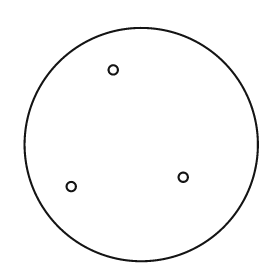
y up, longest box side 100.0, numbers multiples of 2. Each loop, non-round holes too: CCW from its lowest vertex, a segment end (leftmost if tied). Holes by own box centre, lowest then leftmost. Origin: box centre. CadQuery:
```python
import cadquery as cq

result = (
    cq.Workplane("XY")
    .moveTo(0.0, 0.0)
    .circle(50.0)
    .moveTo(-30.0, -18.0)
    .circle(2.0)
    .moveTo(18.0, -14.0)
    .circle(2.0)
    .moveTo(-12.0, 32.0)
    .circle(2.0)
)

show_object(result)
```